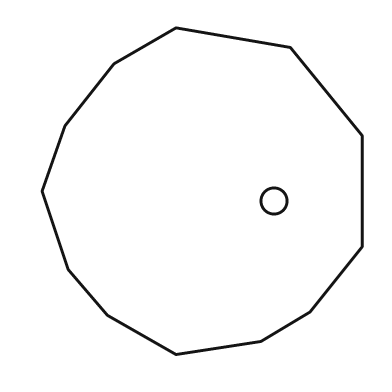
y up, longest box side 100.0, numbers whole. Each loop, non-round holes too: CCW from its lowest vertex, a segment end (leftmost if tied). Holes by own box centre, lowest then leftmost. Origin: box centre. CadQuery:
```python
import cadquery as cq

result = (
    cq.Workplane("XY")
    .moveTo(-8.0, -50.0)
    .lineTo(18.0, -46.0)
    .lineTo(33.0, -37.0)
    .lineTo(49.0, -17.0)
    .lineTo(49.0, 17.0)
    .lineTo(27.0, 44.0)
    .lineTo(-8.0, 50.0)
    .lineTo(-27.0, 39.0)
    .lineTo(-42.0, 20.0)
    .lineTo(-49.0, 0.0)
    .lineTo(-41.0, -24.0)
    .lineTo(-29.0, -38.0)
    .close()
    .moveTo(22.0, -3.0)
    .circle(4.0)
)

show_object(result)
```